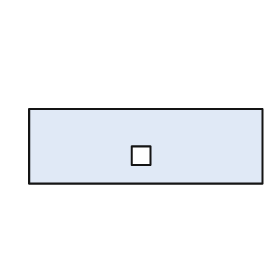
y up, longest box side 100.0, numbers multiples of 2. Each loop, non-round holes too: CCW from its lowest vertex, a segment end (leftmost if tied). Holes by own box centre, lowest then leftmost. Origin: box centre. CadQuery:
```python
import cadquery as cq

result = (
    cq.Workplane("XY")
    .moveTo(-50.0, -16.0)
    .lineTo(50.0, -16.0)
    .lineTo(50.0, 16.0)
    .lineTo(-50.0, 16.0)
    .close()
    .moveTo(-6.0, -8.0)
    .lineTo(2.0, -8.0)
    .lineTo(2.0, 0.0)
    .lineTo(-6.0, 0.0)
    .close()
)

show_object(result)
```